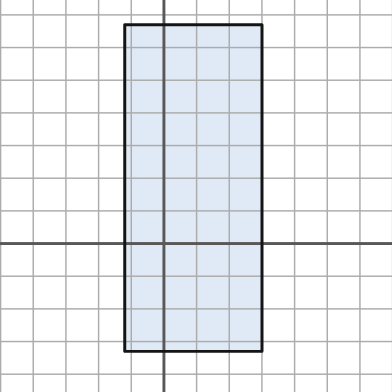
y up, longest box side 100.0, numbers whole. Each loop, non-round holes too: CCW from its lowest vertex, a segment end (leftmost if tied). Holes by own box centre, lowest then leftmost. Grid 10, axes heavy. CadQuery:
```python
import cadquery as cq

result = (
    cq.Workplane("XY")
    .moveTo(-12.0, -33.0)
    .lineTo(30.0, -33.0)
    .lineTo(30.0, 67.0)
    .lineTo(-12.0, 67.0)
    .close()
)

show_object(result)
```